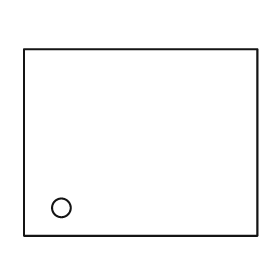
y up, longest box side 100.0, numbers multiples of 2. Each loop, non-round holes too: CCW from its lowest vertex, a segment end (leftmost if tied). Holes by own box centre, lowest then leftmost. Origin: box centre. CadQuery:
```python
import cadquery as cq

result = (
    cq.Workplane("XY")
    .moveTo(-50.0, -40.0)
    .lineTo(50.0, -40.0)
    .lineTo(50.0, 40.0)
    .lineTo(-50.0, 40.0)
    .close()
    .moveTo(-34.0, -28.0)
    .circle(4.0)
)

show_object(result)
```